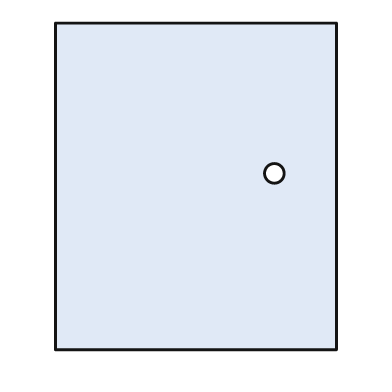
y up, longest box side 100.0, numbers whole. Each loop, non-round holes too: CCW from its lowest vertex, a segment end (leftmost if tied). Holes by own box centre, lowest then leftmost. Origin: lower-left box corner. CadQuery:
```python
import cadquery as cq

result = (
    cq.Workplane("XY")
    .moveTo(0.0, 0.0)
    .lineTo(86.0, 0.0)
    .lineTo(86.0, 100.0)
    .lineTo(0.0, 100.0)
    .close()
    .moveTo(67.0, 54.0)
    .circle(3.0)
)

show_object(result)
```